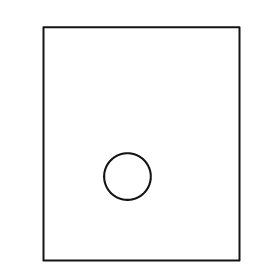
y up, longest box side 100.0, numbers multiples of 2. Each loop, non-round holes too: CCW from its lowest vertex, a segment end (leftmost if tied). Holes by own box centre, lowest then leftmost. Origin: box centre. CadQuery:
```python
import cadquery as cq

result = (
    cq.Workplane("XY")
    .moveTo(-42.0, -50.0)
    .lineTo(42.0, -50.0)
    .lineTo(42.0, 50.0)
    .lineTo(-42.0, 50.0)
    .close()
    .moveTo(-6.0, -14.0)
    .circle(10.0)
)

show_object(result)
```